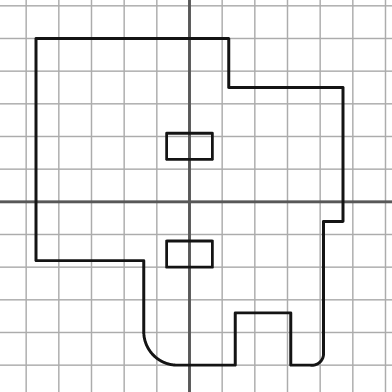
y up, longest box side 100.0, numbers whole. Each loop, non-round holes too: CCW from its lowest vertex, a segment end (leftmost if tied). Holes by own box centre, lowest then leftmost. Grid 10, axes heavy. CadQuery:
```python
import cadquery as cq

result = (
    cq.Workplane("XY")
    .moveTo(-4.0, -50.0)
    .lineTo(14.0, -50.0)
    .lineTo(14.0, -34.0)
    .lineTo(31.0, -34.0)
    .lineTo(31.0, -50.0)
    .lineTo(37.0, -50.0)
    .threePointArc((40.0, -49.0), (41.0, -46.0))
    .lineTo(41.0, -6.0)
    .lineTo(47.0, -6.0)
    .lineTo(47.0, 35.0)
    .lineTo(12.0, 35.0)
    .lineTo(12.0, 50.0)
    .lineTo(-47.0, 50.0)
    .lineTo(-47.0, -18.0)
    .lineTo(-14.0, -18.0)
    .lineTo(-14.0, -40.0)
    .threePointArc((-11.0, -47.0), (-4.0, -50.0))
    .close()
    .moveTo(-7.0, -20.0)
    .lineTo(7.0, -20.0)
    .lineTo(7.0, -12.0)
    .lineTo(-7.0, -12.0)
    .close()
    .moveTo(-7.0, 13.0)
    .lineTo(7.0, 13.0)
    .lineTo(7.0, 21.0)
    .lineTo(-7.0, 21.0)
    .close()
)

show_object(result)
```